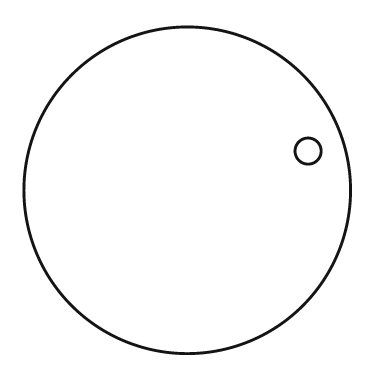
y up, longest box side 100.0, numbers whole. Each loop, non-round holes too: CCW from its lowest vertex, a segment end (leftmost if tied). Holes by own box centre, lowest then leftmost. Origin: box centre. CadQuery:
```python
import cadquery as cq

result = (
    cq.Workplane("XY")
    .moveTo(0.0, 0.0)
    .circle(50.0)
    .moveTo(37.0, 12.0)
    .circle(4.0)
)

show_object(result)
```